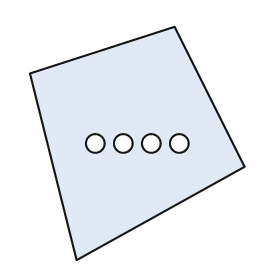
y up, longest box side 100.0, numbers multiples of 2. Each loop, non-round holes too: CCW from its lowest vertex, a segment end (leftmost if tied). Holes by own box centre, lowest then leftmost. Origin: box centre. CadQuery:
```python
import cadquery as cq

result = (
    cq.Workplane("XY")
    .moveTo(-26.0, -50.0)
    .lineTo(46.0, -10.0)
    .lineTo(16.0, 50.0)
    .lineTo(-46.0, 30.0)
    .close()
    .moveTo(-18.0, 0.0)
    .circle(4.0)
    .moveTo(-6.0, 0.0)
    .circle(4.0)
    .moveTo(6.0, 0.0)
    .circle(4.0)
    .moveTo(18.0, 0.0)
    .circle(4.0)
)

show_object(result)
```